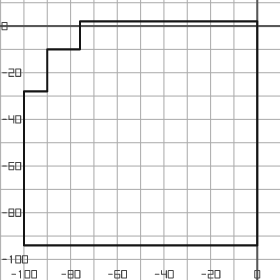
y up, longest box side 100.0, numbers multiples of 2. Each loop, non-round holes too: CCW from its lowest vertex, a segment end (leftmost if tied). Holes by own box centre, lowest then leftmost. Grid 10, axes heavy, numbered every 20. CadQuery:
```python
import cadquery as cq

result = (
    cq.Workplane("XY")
    .moveTo(-100.0, -94.0)
    .lineTo(0.0, -94.0)
    .lineTo(0.0, 2.0)
    .lineTo(-76.0, 2.0)
    .lineTo(-76.0, -10.0)
    .lineTo(-90.0, -10.0)
    .lineTo(-90.0, -28.0)
    .lineTo(-100.0, -28.0)
    .close()
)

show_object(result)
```